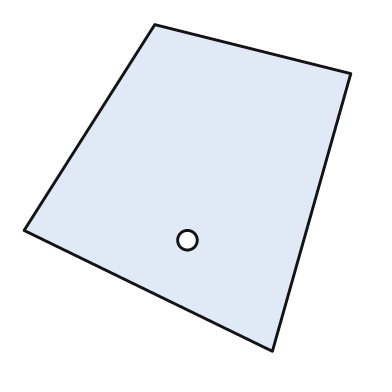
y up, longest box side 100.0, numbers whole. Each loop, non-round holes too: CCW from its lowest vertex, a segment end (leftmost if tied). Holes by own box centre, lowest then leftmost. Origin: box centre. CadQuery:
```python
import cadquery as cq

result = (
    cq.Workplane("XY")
    .moveTo(26.0, -50.0)
    .lineTo(50.0, 35.0)
    .lineTo(-10.0, 50.0)
    .lineTo(-50.0, -13.0)
    .close()
    .moveTo(0.0, -16.0)
    .circle(3.0)
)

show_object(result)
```